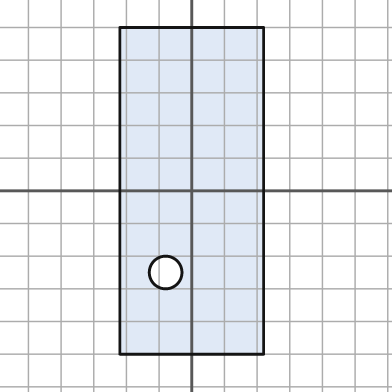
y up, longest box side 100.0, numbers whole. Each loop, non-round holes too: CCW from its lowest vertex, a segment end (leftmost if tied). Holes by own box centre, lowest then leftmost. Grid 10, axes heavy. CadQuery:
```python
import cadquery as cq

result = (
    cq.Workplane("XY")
    .moveTo(-22.0, -50.0)
    .lineTo(22.0, -50.0)
    .lineTo(22.0, 50.0)
    .lineTo(-22.0, 50.0)
    .close()
    .moveTo(-8.0, -25.0)
    .circle(5.0)
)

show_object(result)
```